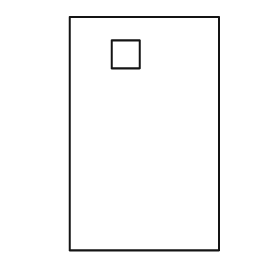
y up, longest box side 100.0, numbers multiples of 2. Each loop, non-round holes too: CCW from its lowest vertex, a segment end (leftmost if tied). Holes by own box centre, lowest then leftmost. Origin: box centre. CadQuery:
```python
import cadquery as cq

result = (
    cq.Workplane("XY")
    .moveTo(-32.0, -50.0)
    .lineTo(32.0, -50.0)
    .lineTo(32.0, 50.0)
    .lineTo(-32.0, 50.0)
    .close()
    .moveTo(-14.0, 28.0)
    .lineTo(-2.0, 28.0)
    .lineTo(-2.0, 40.0)
    .lineTo(-14.0, 40.0)
    .close()
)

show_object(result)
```